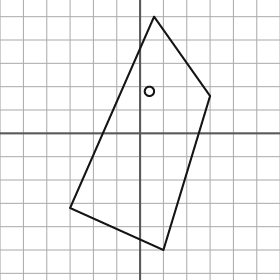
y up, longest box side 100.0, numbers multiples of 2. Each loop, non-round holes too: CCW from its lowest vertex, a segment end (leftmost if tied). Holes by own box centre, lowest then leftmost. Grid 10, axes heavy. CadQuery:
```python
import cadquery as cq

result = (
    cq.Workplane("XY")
    .moveTo(10.0, -50.0)
    .lineTo(30.0, 16.0)
    .lineTo(6.0, 50.0)
    .lineTo(-30.0, -32.0)
    .close()
    .moveTo(4.0, 18.0)
    .circle(2.0)
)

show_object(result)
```